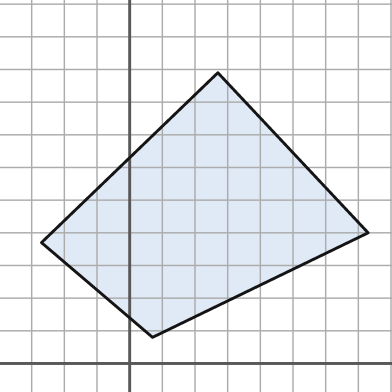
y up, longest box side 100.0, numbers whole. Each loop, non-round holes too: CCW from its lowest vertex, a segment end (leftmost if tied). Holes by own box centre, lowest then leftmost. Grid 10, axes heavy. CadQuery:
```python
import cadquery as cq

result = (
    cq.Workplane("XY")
    .moveTo(7.0, 8.0)
    .lineTo(73.0, 40.0)
    .lineTo(27.0, 89.0)
    .lineTo(-27.0, 37.0)
    .close()
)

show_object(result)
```